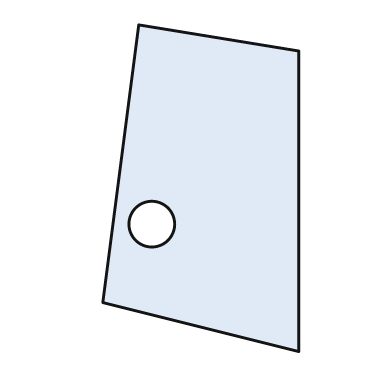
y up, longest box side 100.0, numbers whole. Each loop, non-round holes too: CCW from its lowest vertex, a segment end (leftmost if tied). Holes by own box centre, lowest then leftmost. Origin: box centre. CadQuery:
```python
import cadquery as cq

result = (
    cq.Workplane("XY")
    .moveTo(30.0, -50.0)
    .lineTo(30.0, 42.0)
    .lineTo(-19.0, 50.0)
    .lineTo(-30.0, -35.0)
    .close()
    .moveTo(-15.0, -11.0)
    .circle(7.0)
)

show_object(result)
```